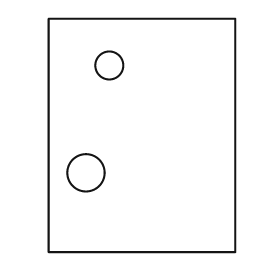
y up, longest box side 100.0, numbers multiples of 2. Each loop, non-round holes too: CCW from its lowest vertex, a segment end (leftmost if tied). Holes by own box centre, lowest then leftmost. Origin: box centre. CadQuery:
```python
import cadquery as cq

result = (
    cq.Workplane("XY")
    .moveTo(-40.0, -50.0)
    .lineTo(40.0, -50.0)
    .lineTo(40.0, 50.0)
    .lineTo(-40.0, 50.0)
    .close()
    .moveTo(-24.0, -16.0)
    .circle(8.0)
    .moveTo(-14.0, 30.0)
    .circle(6.0)
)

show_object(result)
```